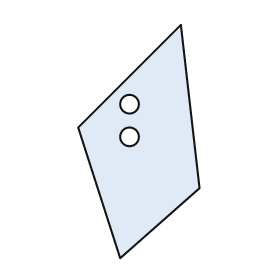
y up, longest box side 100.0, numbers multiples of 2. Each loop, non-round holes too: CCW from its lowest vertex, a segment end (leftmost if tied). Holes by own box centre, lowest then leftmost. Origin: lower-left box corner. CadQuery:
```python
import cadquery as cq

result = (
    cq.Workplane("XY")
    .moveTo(18.0, 0.0)
    .lineTo(52.0, 30.0)
    .lineTo(44.0, 100.0)
    .lineTo(0.0, 56.0)
    .close()
    .moveTo(22.0, 52.0)
    .circle(4.0)
    .moveTo(22.0, 66.0)
    .circle(4.0)
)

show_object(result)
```